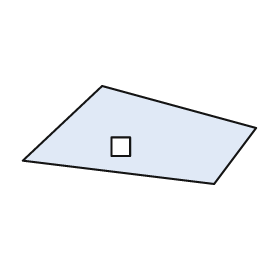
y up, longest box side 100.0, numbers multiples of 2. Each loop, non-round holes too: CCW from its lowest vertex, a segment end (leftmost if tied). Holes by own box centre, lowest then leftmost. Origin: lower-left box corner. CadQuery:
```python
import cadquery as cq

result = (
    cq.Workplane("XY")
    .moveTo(82.0, 0.0)
    .lineTo(100.0, 24.0)
    .lineTo(34.0, 42.0)
    .lineTo(0.0, 10.0)
    .close()
    .moveTo(38.0, 12.0)
    .lineTo(46.0, 12.0)
    .lineTo(46.0, 20.0)
    .lineTo(38.0, 20.0)
    .close()
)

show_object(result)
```